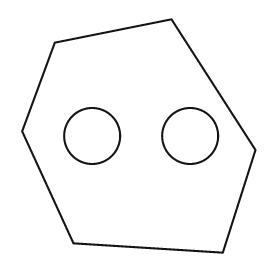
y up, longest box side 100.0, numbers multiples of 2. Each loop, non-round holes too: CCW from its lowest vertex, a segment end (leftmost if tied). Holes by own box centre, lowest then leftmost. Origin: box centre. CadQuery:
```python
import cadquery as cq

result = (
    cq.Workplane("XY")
    .moveTo(36.0, -50.0)
    .lineTo(50.0, -6.0)
    .lineTo(14.0, 50.0)
    .lineTo(-36.0, 40.0)
    .lineTo(-50.0, 2.0)
    .lineTo(-28.0, -46.0)
    .close()
    .moveTo(-20.0, 0.0)
    .circle(12.0)
    .moveTo(22.0, 0.0)
    .circle(12.0)
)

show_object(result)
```